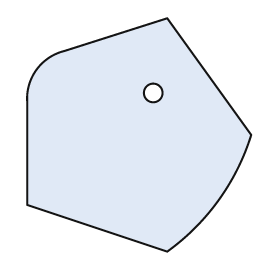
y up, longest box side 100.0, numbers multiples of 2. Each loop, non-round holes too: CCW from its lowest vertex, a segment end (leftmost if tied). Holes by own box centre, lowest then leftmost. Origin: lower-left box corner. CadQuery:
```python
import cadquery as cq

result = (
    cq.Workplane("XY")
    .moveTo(60.0, 0.0)
    .threePointArc((82.0, 22.0), (96.0, 50.0))
    .lineTo(60.0, 100.0)
    .lineTo(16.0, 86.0)
    .threePointArc((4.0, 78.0), (0.0, 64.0))
    .lineTo(0.0, 20.0)
    .close()
    .moveTo(54.0, 68.0)
    .circle(4.0)
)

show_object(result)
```